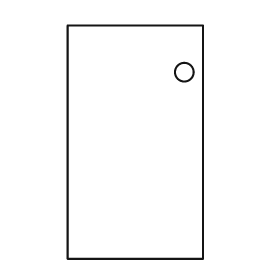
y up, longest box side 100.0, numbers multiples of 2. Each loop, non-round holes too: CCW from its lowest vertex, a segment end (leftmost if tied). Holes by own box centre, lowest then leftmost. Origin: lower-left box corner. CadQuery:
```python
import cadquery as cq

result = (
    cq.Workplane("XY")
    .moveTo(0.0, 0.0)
    .lineTo(58.0, 0.0)
    .lineTo(58.0, 100.0)
    .lineTo(0.0, 100.0)
    .close()
    .moveTo(50.0, 80.0)
    .circle(4.0)
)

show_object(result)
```